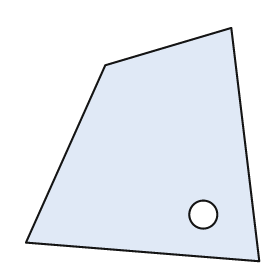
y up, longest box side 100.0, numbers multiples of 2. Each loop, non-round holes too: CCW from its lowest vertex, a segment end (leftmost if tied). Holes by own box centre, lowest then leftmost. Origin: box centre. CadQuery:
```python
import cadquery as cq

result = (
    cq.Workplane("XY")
    .moveTo(50.0, -50.0)
    .lineTo(38.0, 50.0)
    .lineTo(-16.0, 34.0)
    .lineTo(-50.0, -42.0)
    .close()
    .moveTo(26.0, -30.0)
    .circle(6.0)
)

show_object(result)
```